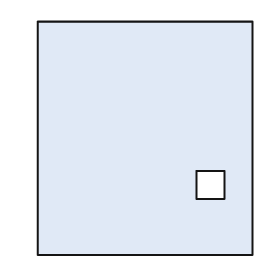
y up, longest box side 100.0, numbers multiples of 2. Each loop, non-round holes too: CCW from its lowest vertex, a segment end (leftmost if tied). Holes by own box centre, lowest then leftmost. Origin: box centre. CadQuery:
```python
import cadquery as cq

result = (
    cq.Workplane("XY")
    .moveTo(-46.0, -50.0)
    .lineTo(46.0, -50.0)
    .lineTo(46.0, 50.0)
    .lineTo(-46.0, 50.0)
    .close()
    .moveTo(22.0, -26.0)
    .lineTo(34.0, -26.0)
    .lineTo(34.0, -14.0)
    .lineTo(22.0, -14.0)
    .close()
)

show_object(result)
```